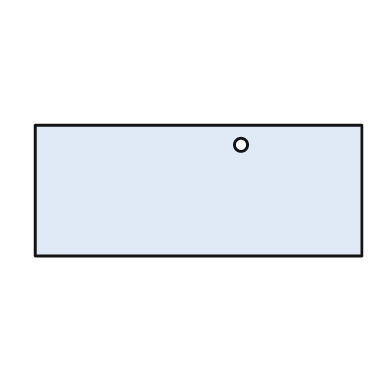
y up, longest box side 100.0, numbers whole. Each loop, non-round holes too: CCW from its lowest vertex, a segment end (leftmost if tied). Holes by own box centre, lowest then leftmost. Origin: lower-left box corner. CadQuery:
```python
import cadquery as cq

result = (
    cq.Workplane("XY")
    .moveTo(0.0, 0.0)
    .lineTo(100.0, 0.0)
    .lineTo(100.0, 40.0)
    .lineTo(0.0, 40.0)
    .close()
    .moveTo(63.0, 34.0)
    .circle(2.0)
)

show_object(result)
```